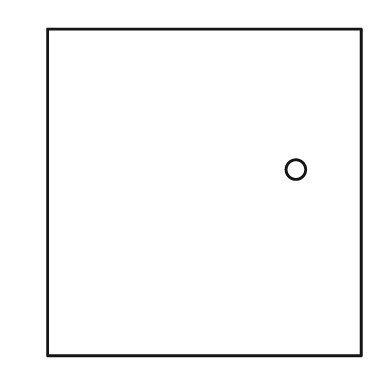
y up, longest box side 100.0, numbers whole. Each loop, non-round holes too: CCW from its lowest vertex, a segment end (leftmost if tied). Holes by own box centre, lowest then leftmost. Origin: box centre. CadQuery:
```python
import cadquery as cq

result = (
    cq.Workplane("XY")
    .moveTo(-48.0, -50.0)
    .lineTo(48.0, -50.0)
    .lineTo(48.0, 50.0)
    .lineTo(-48.0, 50.0)
    .close()
    .moveTo(28.0, 7.0)
    .circle(3.0)
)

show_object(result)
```